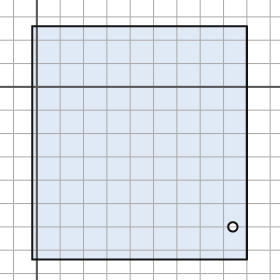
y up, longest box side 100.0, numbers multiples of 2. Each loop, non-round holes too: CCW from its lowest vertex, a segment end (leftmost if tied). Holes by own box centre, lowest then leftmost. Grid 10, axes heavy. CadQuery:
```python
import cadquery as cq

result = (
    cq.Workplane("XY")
    .moveTo(-2.0, -74.0)
    .lineTo(90.0, -74.0)
    .lineTo(90.0, 26.0)
    .lineTo(-2.0, 26.0)
    .close()
    .moveTo(84.0, -60.0)
    .circle(2.0)
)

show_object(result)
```